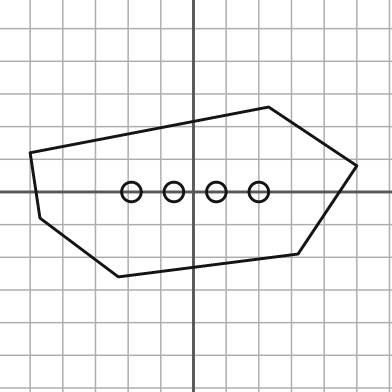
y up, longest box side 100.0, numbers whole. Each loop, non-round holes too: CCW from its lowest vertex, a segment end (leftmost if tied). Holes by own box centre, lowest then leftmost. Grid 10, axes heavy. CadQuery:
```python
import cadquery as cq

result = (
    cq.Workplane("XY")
    .moveTo(-23.0, -26.0)
    .lineTo(32.0, -19.0)
    .lineTo(50.0, 8.0)
    .lineTo(23.0, 26.0)
    .lineTo(-50.0, 12.0)
    .lineTo(-47.0, -8.0)
    .close()
    .moveTo(-19.0, 0.0)
    .circle(3.0)
    .moveTo(-6.0, 0.0)
    .circle(3.0)
    .moveTo(7.0, 0.0)
    .circle(3.0)
    .moveTo(20.0, 0.0)
    .circle(3.0)
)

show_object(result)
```